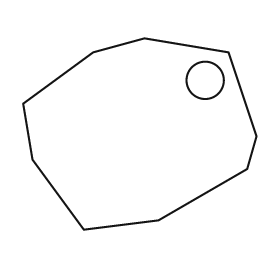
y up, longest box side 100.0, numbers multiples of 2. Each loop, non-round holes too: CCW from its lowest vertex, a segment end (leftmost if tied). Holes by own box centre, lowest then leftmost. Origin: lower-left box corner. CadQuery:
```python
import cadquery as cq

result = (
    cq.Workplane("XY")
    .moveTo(26.0, 0.0)
    .lineTo(58.0, 4.0)
    .lineTo(96.0, 26.0)
    .lineTo(100.0, 40.0)
    .lineTo(88.0, 76.0)
    .lineTo(52.0, 82.0)
    .lineTo(30.0, 76.0)
    .lineTo(0.0, 54.0)
    .lineTo(4.0, 30.0)
    .close()
    .moveTo(78.0, 64.0)
    .circle(8.0)
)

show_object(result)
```